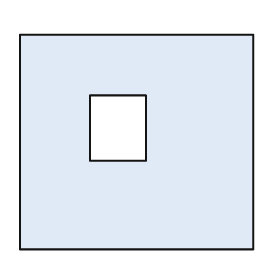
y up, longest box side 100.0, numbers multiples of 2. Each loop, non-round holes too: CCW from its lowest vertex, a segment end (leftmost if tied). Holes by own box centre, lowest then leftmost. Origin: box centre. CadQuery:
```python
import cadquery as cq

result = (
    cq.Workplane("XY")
    .moveTo(-50.0, -46.0)
    .lineTo(50.0, -46.0)
    .lineTo(50.0, 46.0)
    .lineTo(-50.0, 46.0)
    .close()
    .moveTo(-20.0, -8.0)
    .lineTo(4.0, -8.0)
    .lineTo(4.0, 20.0)
    .lineTo(-20.0, 20.0)
    .close()
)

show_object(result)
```